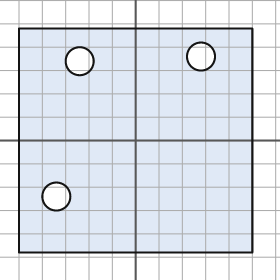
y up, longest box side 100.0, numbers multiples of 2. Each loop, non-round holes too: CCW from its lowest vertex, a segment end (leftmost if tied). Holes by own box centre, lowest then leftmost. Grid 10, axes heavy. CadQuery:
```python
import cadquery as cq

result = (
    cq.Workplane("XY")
    .moveTo(-50.0, -48.0)
    .lineTo(50.0, -48.0)
    .lineTo(50.0, 48.0)
    .lineTo(-50.0, 48.0)
    .close()
    .moveTo(-34.0, -24.0)
    .circle(6.0)
    .moveTo(-24.0, 34.0)
    .circle(6.0)
    .moveTo(28.0, 36.0)
    .circle(6.0)
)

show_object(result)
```